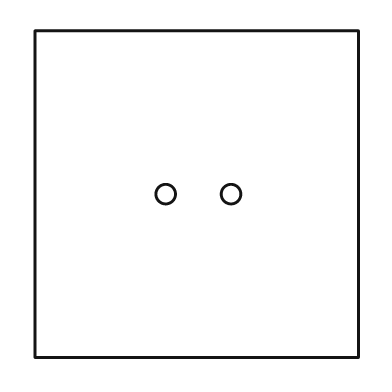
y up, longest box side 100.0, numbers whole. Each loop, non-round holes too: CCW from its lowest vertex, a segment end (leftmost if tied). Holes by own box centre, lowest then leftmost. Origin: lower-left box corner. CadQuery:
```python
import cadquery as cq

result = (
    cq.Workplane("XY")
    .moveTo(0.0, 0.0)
    .lineTo(99.0, 0.0)
    .lineTo(99.0, 100.0)
    .lineTo(0.0, 100.0)
    .close()
    .moveTo(40.0, 50.0)
    .circle(3.0)
    .moveTo(60.0, 50.0)
    .circle(3.0)
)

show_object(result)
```